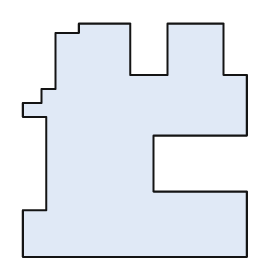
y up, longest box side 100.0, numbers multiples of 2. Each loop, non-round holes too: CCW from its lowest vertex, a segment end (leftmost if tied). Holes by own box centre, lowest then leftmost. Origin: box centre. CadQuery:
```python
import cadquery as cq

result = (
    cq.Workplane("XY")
    .moveTo(-48.0, -50.0)
    .lineTo(48.0, -50.0)
    .lineTo(48.0, -22.0)
    .lineTo(8.0, -22.0)
    .lineTo(8.0, 2.0)
    .lineTo(48.0, 2.0)
    .lineTo(48.0, 28.0)
    .lineTo(38.0, 28.0)
    .lineTo(38.0, 50.0)
    .lineTo(14.0, 50.0)
    .lineTo(14.0, 28.0)
    .lineTo(-2.0, 28.0)
    .lineTo(-2.0, 50.0)
    .lineTo(-24.0, 50.0)
    .lineTo(-24.0, 46.0)
    .lineTo(-34.0, 46.0)
    .lineTo(-34.0, 22.0)
    .lineTo(-40.0, 22.0)
    .lineTo(-40.0, 16.0)
    .lineTo(-48.0, 16.0)
    .lineTo(-48.0, 10.0)
    .lineTo(-38.0, 10.0)
    .lineTo(-38.0, -30.0)
    .lineTo(-48.0, -30.0)
    .close()
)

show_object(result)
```